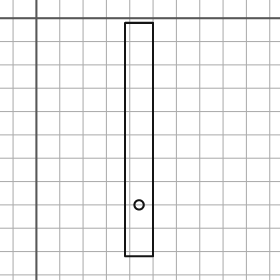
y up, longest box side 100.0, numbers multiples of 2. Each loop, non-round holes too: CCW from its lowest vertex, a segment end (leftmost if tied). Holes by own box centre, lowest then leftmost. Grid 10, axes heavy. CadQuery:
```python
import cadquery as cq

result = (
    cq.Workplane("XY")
    .moveTo(38.0, -102.0)
    .lineTo(50.0, -102.0)
    .lineTo(50.0, -2.0)
    .lineTo(38.0, -2.0)
    .close()
    .moveTo(44.0, -80.0)
    .circle(2.0)
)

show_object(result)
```